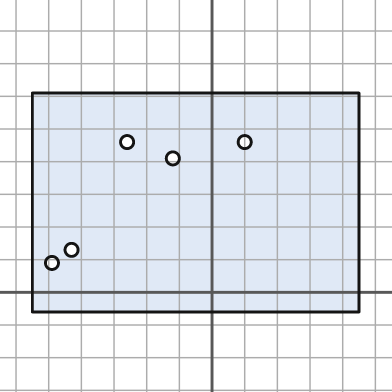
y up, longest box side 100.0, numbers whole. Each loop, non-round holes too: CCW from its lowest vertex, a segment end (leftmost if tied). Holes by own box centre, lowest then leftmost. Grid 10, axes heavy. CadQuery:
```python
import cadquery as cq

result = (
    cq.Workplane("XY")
    .moveTo(-55.0, -6.0)
    .lineTo(45.0, -6.0)
    .lineTo(45.0, 61.0)
    .lineTo(-55.0, 61.0)
    .close()
    .moveTo(-49.0, 9.0)
    .circle(2.0)
    .moveTo(-43.0, 13.0)
    .circle(2.0)
    .moveTo(-12.0, 41.0)
    .circle(2.0)
    .moveTo(-26.0, 46.0)
    .circle(2.0)
    .moveTo(10.0, 46.0)
    .circle(2.0)
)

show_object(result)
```